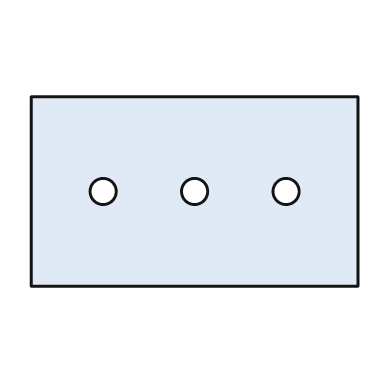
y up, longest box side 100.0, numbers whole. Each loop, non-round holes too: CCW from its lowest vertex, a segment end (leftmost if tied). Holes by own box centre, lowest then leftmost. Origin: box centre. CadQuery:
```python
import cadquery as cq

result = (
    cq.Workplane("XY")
    .moveTo(-50.0, -29.0)
    .lineTo(50.0, -29.0)
    .lineTo(50.0, 29.0)
    .lineTo(-50.0, 29.0)
    .close()
    .moveTo(-28.0, 0.0)
    .circle(4.0)
    .moveTo(0.0, 0.0)
    .circle(4.0)
    .moveTo(28.0, 0.0)
    .circle(4.0)
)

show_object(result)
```